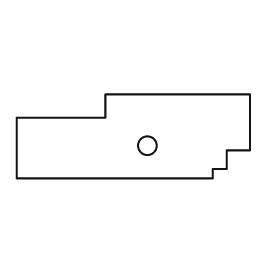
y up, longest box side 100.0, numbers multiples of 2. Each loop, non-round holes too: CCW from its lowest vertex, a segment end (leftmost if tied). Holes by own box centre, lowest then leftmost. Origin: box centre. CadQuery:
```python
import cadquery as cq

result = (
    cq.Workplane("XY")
    .moveTo(-50.0, -18.0)
    .lineTo(34.0, -18.0)
    .lineTo(34.0, -14.0)
    .lineTo(40.0, -14.0)
    .lineTo(40.0, -6.0)
    .lineTo(50.0, -6.0)
    .lineTo(50.0, 18.0)
    .lineTo(-12.0, 18.0)
    .lineTo(-12.0, 8.0)
    .lineTo(-50.0, 8.0)
    .close()
    .moveTo(6.0, -4.0)
    .circle(4.0)
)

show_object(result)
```